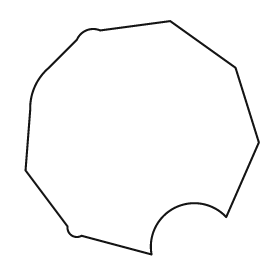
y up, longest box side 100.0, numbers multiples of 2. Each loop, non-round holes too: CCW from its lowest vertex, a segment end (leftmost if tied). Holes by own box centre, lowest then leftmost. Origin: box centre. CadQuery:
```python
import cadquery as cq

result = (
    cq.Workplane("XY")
    .moveTo(4.0, -50.0)
    .threePointArc((14.0, -30.0), (36.0, -34.0))
    .lineTo(50.0, -2.0)
    .lineTo(40.0, 30.0)
    .lineTo(12.0, 50.0)
    .lineTo(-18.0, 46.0)
    .threePointArc((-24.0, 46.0), (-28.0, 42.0))
    .lineTo(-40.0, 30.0)
    .threePointArc((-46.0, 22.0), (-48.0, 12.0))
    .lineTo(-50.0, -14.0)
    .lineTo(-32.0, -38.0)
    .threePointArc((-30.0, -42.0), (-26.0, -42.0))
    .close()
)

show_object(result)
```